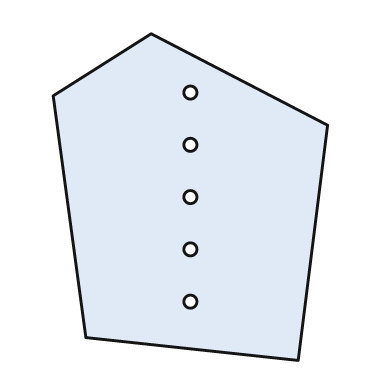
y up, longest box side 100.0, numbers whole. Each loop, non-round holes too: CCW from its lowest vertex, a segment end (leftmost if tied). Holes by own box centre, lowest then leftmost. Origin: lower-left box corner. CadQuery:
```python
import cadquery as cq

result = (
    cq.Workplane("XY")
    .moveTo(75.0, 0.0)
    .lineTo(84.0, 72.0)
    .lineTo(30.0, 100.0)
    .lineTo(0.0, 81.0)
    .lineTo(10.0, 7.0)
    .close()
    .moveTo(42.0, 18.0)
    .circle(2.0)
    .moveTo(42.0, 34.0)
    .circle(2.0)
    .moveTo(42.0, 50.0)
    .circle(2.0)
    .moveTo(42.0, 66.0)
    .circle(2.0)
    .moveTo(42.0, 82.0)
    .circle(2.0)
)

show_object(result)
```